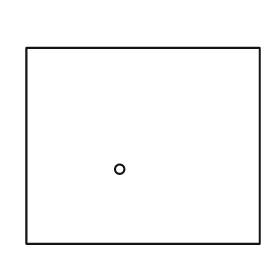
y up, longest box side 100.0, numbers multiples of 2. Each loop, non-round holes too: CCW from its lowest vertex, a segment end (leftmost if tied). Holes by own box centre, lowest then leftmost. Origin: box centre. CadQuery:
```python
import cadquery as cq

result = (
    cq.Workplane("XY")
    .moveTo(-50.0, -42.0)
    .lineTo(50.0, -42.0)
    .lineTo(50.0, 42.0)
    .lineTo(-50.0, 42.0)
    .close()
    .moveTo(-10.0, -10.0)
    .circle(2.0)
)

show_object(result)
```